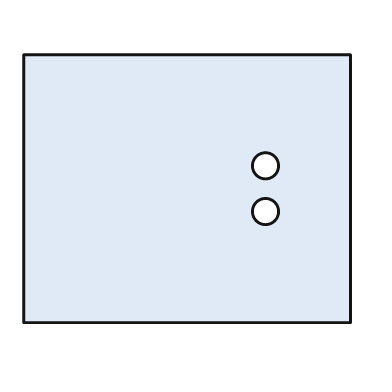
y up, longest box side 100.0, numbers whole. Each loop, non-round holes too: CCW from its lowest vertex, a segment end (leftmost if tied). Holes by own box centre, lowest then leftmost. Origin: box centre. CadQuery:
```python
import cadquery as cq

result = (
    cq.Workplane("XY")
    .moveTo(-50.0, -41.0)
    .lineTo(50.0, -41.0)
    .lineTo(50.0, 41.0)
    .lineTo(-50.0, 41.0)
    .close()
    .moveTo(24.0, -7.0)
    .circle(4.0)
    .moveTo(24.0, 7.0)
    .circle(4.0)
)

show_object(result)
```